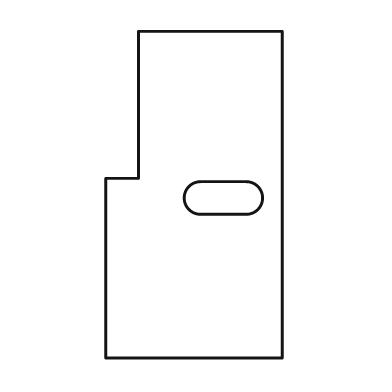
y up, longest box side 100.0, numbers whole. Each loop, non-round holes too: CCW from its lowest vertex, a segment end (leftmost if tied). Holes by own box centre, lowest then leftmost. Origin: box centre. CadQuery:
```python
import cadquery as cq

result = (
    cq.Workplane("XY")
    .moveTo(-27.0, -50.0)
    .lineTo(27.0, -50.0)
    .lineTo(27.0, 50.0)
    .lineTo(-17.0, 50.0)
    .lineTo(-17.0, 5.0)
    .lineTo(-27.0, 5.0)
    .close()
    .moveTo(2.0, -6.0)
    .lineTo(16.0, -6.0)
    .threePointArc((21.0, -1.0), (16.0, 4.0))
    .lineTo(2.0, 4.0)
    .threePointArc((-3.0, -1.0), (2.0, -6.0))
    .close()
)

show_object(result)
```